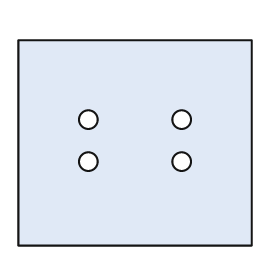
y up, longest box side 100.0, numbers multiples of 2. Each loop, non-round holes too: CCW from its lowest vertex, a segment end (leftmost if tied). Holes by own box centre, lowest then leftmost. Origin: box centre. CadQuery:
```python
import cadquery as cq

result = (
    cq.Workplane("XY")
    .moveTo(-50.0, -44.0)
    .lineTo(50.0, -44.0)
    .lineTo(50.0, 44.0)
    .lineTo(-50.0, 44.0)
    .close()
    .moveTo(-20.0, -8.0)
    .circle(4.0)
    .moveTo(20.0, -8.0)
    .circle(4.0)
    .moveTo(-20.0, 10.0)
    .circle(4.0)
    .moveTo(20.0, 10.0)
    .circle(4.0)
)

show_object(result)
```